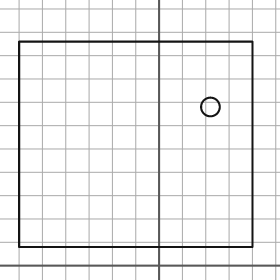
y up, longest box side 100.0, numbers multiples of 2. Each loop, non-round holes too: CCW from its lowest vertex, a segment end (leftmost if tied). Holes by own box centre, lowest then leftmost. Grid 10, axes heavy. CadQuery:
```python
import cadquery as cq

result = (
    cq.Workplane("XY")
    .moveTo(-60.0, 8.0)
    .lineTo(40.0, 8.0)
    .lineTo(40.0, 96.0)
    .lineTo(-60.0, 96.0)
    .close()
    .moveTo(22.0, 68.0)
    .circle(4.0)
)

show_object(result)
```